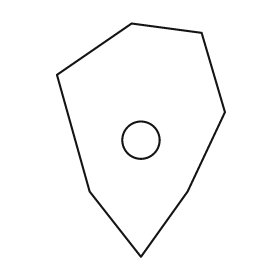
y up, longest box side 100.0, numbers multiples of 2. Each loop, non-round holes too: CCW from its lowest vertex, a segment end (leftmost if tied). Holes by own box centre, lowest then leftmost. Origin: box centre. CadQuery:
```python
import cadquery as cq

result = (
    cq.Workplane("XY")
    .moveTo(0.0, -50.0)
    .lineTo(20.0, -22.0)
    .lineTo(36.0, 12.0)
    .lineTo(26.0, 46.0)
    .lineTo(-4.0, 50.0)
    .lineTo(-36.0, 28.0)
    .lineTo(-22.0, -22.0)
    .close()
    .moveTo(0.0, 0.0)
    .circle(8.0)
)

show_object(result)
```